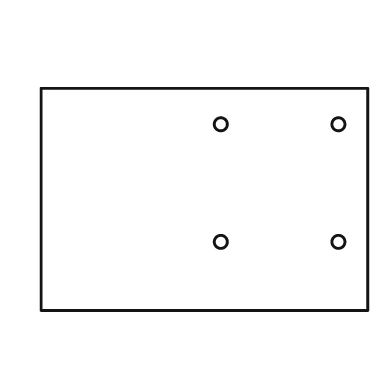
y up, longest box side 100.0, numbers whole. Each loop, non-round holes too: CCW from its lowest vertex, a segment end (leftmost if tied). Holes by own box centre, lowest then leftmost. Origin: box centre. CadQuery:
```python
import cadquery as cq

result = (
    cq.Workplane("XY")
    .moveTo(-50.0, -34.0)
    .lineTo(50.0, -34.0)
    .lineTo(50.0, 34.0)
    .lineTo(-50.0, 34.0)
    .close()
    .moveTo(5.0, -13.0)
    .circle(2.0)
    .moveTo(41.0, -13.0)
    .circle(2.0)
    .moveTo(5.0, 23.0)
    .circle(2.0)
    .moveTo(41.0, 23.0)
    .circle(2.0)
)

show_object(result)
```